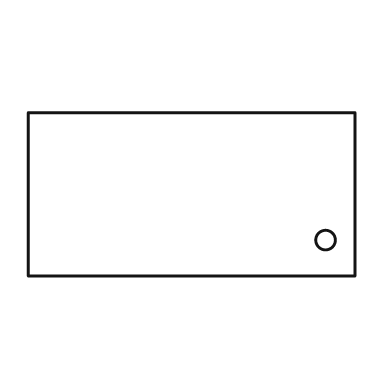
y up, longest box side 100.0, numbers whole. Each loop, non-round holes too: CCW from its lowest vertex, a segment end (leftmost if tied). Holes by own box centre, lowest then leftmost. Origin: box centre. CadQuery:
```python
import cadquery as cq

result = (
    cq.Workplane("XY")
    .moveTo(-50.0, -25.0)
    .lineTo(50.0, -25.0)
    .lineTo(50.0, 25.0)
    .lineTo(-50.0, 25.0)
    .close()
    .moveTo(41.0, -14.0)
    .circle(3.0)
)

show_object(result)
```